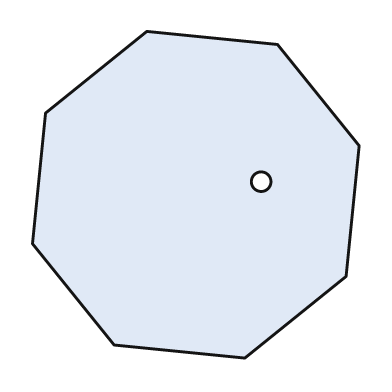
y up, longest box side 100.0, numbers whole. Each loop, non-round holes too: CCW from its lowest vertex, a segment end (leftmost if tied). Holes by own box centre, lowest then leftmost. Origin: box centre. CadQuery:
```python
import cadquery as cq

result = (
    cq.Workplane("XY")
    .moveTo(15.0, -50.0)
    .lineTo(46.0, -25.0)
    .lineTo(50.0, 15.0)
    .lineTo(25.0, 46.0)
    .lineTo(-15.0, 50.0)
    .lineTo(-46.0, 25.0)
    .lineTo(-50.0, -15.0)
    .lineTo(-25.0, -46.0)
    .close()
    .moveTo(20.0, 4.0)
    .circle(3.0)
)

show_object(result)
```